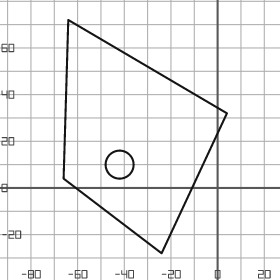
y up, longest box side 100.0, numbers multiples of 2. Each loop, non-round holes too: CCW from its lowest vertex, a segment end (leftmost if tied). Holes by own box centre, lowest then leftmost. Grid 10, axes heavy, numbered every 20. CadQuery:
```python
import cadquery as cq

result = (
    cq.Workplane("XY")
    .moveTo(-24.0, -28.0)
    .lineTo(4.0, 32.0)
    .lineTo(-64.0, 72.0)
    .lineTo(-66.0, 4.0)
    .close()
    .moveTo(-42.0, 10.0)
    .circle(6.0)
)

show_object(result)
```